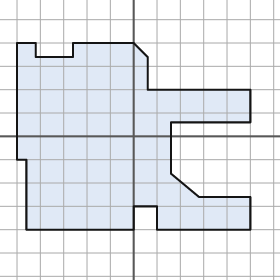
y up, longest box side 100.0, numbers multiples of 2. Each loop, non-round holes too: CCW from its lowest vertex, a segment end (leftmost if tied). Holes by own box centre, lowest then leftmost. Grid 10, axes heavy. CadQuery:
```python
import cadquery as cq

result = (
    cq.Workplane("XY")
    .moveTo(-46.0, -40.0)
    .lineTo(0.0, -40.0)
    .lineTo(0.0, -30.0)
    .lineTo(10.0, -30.0)
    .lineTo(10.0, -40.0)
    .lineTo(50.0, -40.0)
    .lineTo(50.0, -26.0)
    .lineTo(28.0, -26.0)
    .lineTo(16.0, -16.0)
    .lineTo(16.0, 6.0)
    .lineTo(50.0, 6.0)
    .lineTo(50.0, 20.0)
    .lineTo(6.0, 20.0)
    .lineTo(6.0, 34.0)
    .lineTo(0.0, 40.0)
    .lineTo(-26.0, 40.0)
    .lineTo(-26.0, 34.0)
    .lineTo(-42.0, 34.0)
    .lineTo(-42.0, 40.0)
    .lineTo(-50.0, 40.0)
    .lineTo(-50.0, -10.0)
    .lineTo(-46.0, -10.0)
    .close()
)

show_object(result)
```